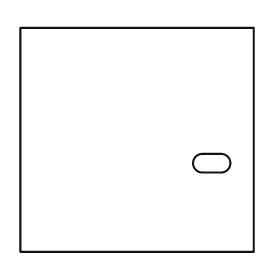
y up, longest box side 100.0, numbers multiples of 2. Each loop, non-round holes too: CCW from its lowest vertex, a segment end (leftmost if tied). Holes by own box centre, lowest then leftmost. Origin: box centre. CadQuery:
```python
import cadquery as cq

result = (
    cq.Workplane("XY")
    .moveTo(-50.0, -48.0)
    .lineTo(50.0, -48.0)
    .lineTo(50.0, 48.0)
    .lineTo(-50.0, 48.0)
    .close()
    .moveTo(28.0, -14.0)
    .lineTo(36.0, -14.0)
    .threePointArc((40.0, -10.0), (36.0, -6.0))
    .lineTo(28.0, -6.0)
    .threePointArc((24.0, -10.0), (28.0, -14.0))
    .close()
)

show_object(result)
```